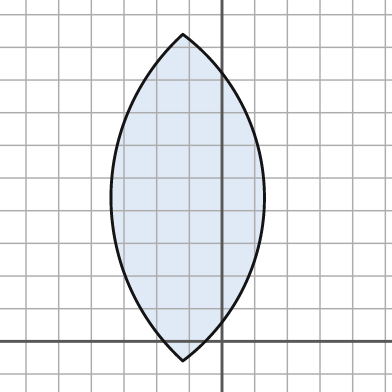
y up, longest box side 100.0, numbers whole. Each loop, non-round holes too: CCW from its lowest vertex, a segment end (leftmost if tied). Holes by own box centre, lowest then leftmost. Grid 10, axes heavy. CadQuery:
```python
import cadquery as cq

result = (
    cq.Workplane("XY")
    .moveTo(-12.0, -6.0)
    .threePointArc((13.0, 44.0), (-12.0, 94.0))
    .threePointArc((-34.0, 44.0), (-12.0, -6.0))
    .close()
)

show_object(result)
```